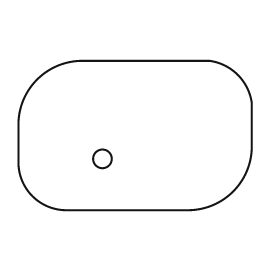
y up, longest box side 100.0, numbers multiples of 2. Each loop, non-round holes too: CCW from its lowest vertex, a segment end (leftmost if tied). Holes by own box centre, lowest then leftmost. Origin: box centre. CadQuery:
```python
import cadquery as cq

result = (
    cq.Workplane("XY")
    .moveTo(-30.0, -32.0)
    .lineTo(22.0, -32.0)
    .threePointArc((42.0, -24.0), (50.0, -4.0))
    .lineTo(50.0, 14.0)
    .threePointArc((44.0, 26.0), (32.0, 32.0))
    .lineTo(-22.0, 32.0)
    .threePointArc((-42.0, 24.0), (-50.0, 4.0))
    .lineTo(-50.0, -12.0)
    .threePointArc((-44.0, -26.0), (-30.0, -32.0))
    .close()
    .moveTo(-14.0, -10.0)
    .circle(4.0)
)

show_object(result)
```